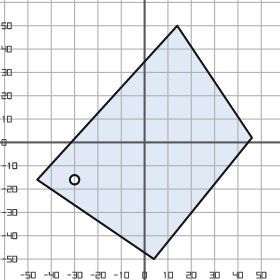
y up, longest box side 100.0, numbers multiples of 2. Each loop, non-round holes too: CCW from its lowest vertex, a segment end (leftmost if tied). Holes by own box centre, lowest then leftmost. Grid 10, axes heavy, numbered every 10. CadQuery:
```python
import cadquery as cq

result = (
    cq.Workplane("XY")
    .moveTo(4.0, -50.0)
    .lineTo(46.0, 2.0)
    .lineTo(14.0, 50.0)
    .lineTo(-46.0, -16.0)
    .close()
    .moveTo(-30.0, -16.0)
    .circle(2.0)
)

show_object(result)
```